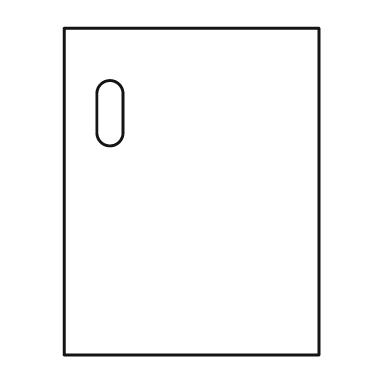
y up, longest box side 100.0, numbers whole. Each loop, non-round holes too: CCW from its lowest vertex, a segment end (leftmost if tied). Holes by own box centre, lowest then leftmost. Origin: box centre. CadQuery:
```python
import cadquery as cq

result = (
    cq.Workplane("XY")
    .moveTo(-39.0, -50.0)
    .lineTo(39.0, -50.0)
    .lineTo(39.0, 50.0)
    .lineTo(-39.0, 50.0)
    .close()
    .moveTo(-29.0, 18.0)
    .threePointArc((-25.0, 14.0), (-21.0, 18.0))
    .lineTo(-21.0, 30.0)
    .threePointArc((-25.0, 34.0), (-29.0, 30.0))
    .close()
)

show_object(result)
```